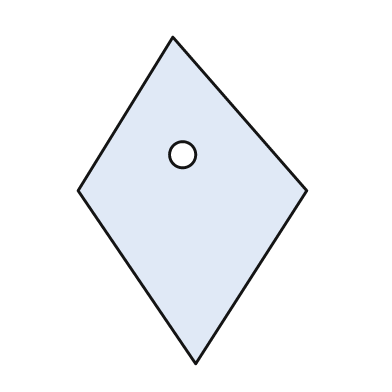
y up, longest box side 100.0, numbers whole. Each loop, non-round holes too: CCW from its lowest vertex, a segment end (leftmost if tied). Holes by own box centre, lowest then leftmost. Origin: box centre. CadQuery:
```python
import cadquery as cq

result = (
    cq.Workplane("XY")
    .moveTo(1.0, -50.0)
    .lineTo(35.0, 3.0)
    .lineTo(-6.0, 50.0)
    .lineTo(-35.0, 3.0)
    .close()
    .moveTo(-3.0, 14.0)
    .circle(4.0)
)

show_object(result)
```